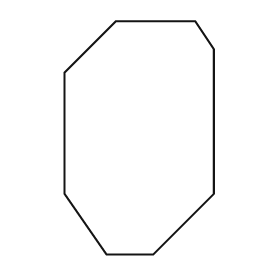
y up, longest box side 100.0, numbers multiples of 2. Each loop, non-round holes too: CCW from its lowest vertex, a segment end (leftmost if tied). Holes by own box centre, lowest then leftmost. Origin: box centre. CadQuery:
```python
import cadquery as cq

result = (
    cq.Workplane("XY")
    .moveTo(-14.0, -50.0)
    .lineTo(6.0, -50.0)
    .lineTo(32.0, -24.0)
    .lineTo(32.0, 38.0)
    .lineTo(24.0, 50.0)
    .lineTo(-10.0, 50.0)
    .lineTo(-32.0, 28.0)
    .lineTo(-32.0, -24.0)
    .close()
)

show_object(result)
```